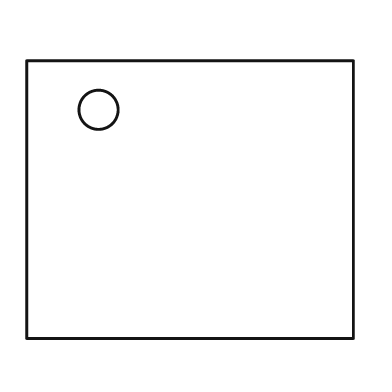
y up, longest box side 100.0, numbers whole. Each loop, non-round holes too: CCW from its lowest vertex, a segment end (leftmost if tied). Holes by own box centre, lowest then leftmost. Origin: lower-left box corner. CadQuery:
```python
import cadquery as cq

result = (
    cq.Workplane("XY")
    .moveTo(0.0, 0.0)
    .lineTo(100.0, 0.0)
    .lineTo(100.0, 85.0)
    .lineTo(0.0, 85.0)
    .close()
    .moveTo(22.0, 70.0)
    .circle(6.0)
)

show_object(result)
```